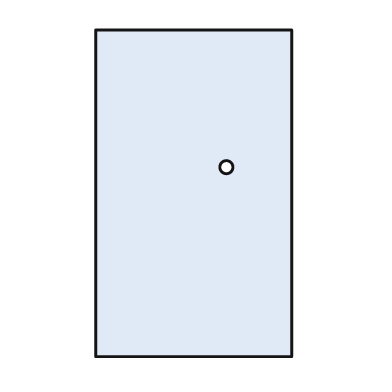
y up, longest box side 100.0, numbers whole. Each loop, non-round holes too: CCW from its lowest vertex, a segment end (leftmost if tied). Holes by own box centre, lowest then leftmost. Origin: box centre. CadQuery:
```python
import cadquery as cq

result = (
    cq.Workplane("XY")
    .moveTo(-30.0, -50.0)
    .lineTo(30.0, -50.0)
    .lineTo(30.0, 50.0)
    .lineTo(-30.0, 50.0)
    .close()
    .moveTo(10.0, 8.0)
    .circle(2.0)
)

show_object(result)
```